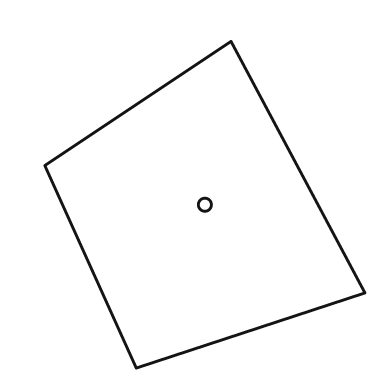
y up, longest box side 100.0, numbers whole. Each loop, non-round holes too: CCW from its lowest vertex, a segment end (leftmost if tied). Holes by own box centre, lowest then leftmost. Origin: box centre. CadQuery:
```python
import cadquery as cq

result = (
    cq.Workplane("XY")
    .moveTo(-21.0, -50.0)
    .lineTo(49.0, -27.0)
    .lineTo(8.0, 50.0)
    .lineTo(-49.0, 12.0)
    .close()
    .moveTo(0.0, 0.0)
    .circle(2.0)
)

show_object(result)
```